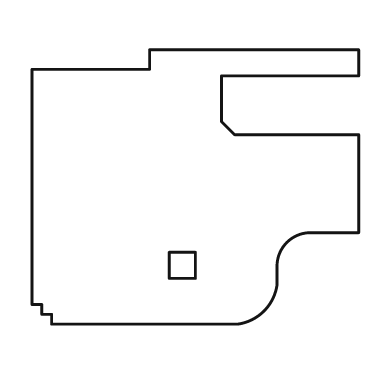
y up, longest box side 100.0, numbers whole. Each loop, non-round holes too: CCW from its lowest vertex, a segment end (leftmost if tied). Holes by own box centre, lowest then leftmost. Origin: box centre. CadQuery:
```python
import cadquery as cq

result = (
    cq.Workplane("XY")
    .moveTo(-44.0, -42.0)
    .lineTo(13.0, -42.0)
    .threePointArc((21.0, -38.0), (25.0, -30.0))
    .lineTo(25.0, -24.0)
    .threePointArc((28.0, -17.0), (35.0, -14.0))
    .lineTo(50.0, -14.0)
    .lineTo(50.0, 16.0)
    .lineTo(12.0, 16.0)
    .lineTo(8.0, 20.0)
    .lineTo(8.0, 34.0)
    .lineTo(50.0, 34.0)
    .lineTo(50.0, 42.0)
    .lineTo(-14.0, 42.0)
    .lineTo(-14.0, 36.0)
    .lineTo(-50.0, 36.0)
    .lineTo(-50.0, -36.0)
    .lineTo(-47.0, -36.0)
    .lineTo(-47.0, -39.0)
    .lineTo(-44.0, -39.0)
    .close()
    .moveTo(-8.0, -28.0)
    .lineTo(0.0, -28.0)
    .lineTo(0.0, -20.0)
    .lineTo(-8.0, -20.0)
    .close()
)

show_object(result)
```